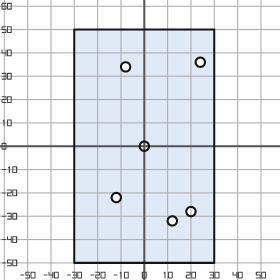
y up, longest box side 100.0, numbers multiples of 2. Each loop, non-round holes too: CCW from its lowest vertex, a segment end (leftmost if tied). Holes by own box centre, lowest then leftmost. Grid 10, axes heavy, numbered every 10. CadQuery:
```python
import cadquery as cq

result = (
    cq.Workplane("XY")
    .moveTo(-30.0, -50.0)
    .lineTo(30.0, -50.0)
    .lineTo(30.0, 50.0)
    .lineTo(-30.0, 50.0)
    .close()
    .moveTo(12.0, -32.0)
    .circle(2.0)
    .moveTo(20.0, -28.0)
    .circle(2.0)
    .moveTo(-12.0, -22.0)
    .circle(2.0)
    .moveTo(0.0, 0.0)
    .circle(2.0)
    .moveTo(-8.0, 34.0)
    .circle(2.0)
    .moveTo(24.0, 36.0)
    .circle(2.0)
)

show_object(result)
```